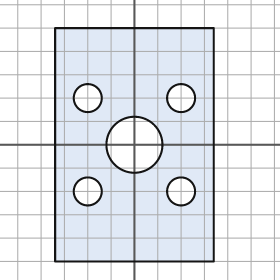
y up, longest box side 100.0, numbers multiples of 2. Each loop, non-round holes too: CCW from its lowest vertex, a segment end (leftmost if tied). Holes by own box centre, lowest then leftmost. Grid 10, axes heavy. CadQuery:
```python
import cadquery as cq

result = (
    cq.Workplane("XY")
    .moveTo(-34.0, -50.0)
    .lineTo(34.0, -50.0)
    .lineTo(34.0, 50.0)
    .lineTo(-34.0, 50.0)
    .close()
    .moveTo(-20.0, -20.0)
    .circle(6.0)
    .moveTo(20.0, -20.0)
    .circle(6.0)
    .moveTo(0.0, 0.0)
    .circle(12.0)
    .moveTo(-20.0, 20.0)
    .circle(6.0)
    .moveTo(20.0, 20.0)
    .circle(6.0)
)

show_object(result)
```